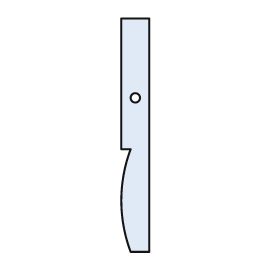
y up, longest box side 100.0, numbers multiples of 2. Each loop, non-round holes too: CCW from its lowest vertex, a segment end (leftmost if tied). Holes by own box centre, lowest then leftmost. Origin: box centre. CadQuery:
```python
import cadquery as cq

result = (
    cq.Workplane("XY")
    .moveTo(-2.0, -50.0)
    .lineTo(6.0, -50.0)
    .lineTo(6.0, 50.0)
    .lineTo(-6.0, 50.0)
    .lineTo(-6.0, -6.0)
    .lineTo(-2.0, -6.0)
    .threePointArc((-6.0, -28.0), (-2.0, -50.0))
    .close()
    .moveTo(0.0, 16.0)
    .circle(2.0)
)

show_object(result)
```